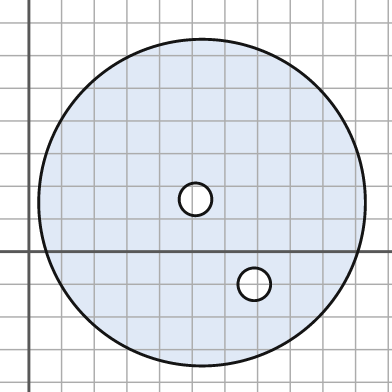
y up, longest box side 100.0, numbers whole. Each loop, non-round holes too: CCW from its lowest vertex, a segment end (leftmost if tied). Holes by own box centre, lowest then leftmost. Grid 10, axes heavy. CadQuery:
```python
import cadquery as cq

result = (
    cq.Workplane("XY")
    .moveTo(53.0, 15.0)
    .circle(50.0)
    .moveTo(69.0, -10.0)
    .circle(5.0)
    .moveTo(51.0, 16.0)
    .circle(5.0)
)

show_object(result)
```